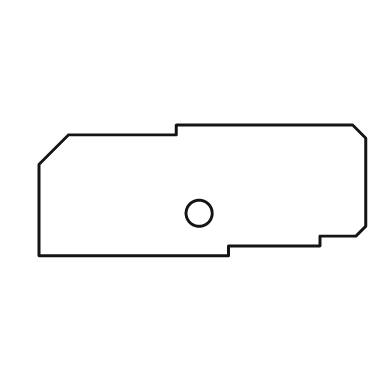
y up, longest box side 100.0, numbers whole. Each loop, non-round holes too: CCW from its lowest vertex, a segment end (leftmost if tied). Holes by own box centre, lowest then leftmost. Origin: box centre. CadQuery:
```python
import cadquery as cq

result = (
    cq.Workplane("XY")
    .moveTo(-50.0, -20.0)
    .lineTo(8.0, -20.0)
    .lineTo(8.0, -17.0)
    .lineTo(36.0, -17.0)
    .lineTo(36.0, -14.0)
    .lineTo(47.0, -14.0)
    .lineTo(50.0, -11.0)
    .lineTo(50.0, 16.0)
    .lineTo(46.0, 20.0)
    .lineTo(-8.0, 20.0)
    .lineTo(-8.0, 17.0)
    .lineTo(-41.0, 17.0)
    .lineTo(-50.0, 8.0)
    .close()
    .moveTo(-1.0, -7.0)
    .circle(4.0)
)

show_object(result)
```